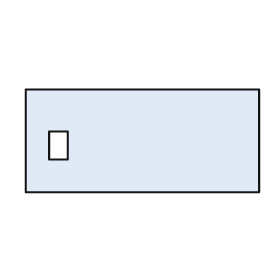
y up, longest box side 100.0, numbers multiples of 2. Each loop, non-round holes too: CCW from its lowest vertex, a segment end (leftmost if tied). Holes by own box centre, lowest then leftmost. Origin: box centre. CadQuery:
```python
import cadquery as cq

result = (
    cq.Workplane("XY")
    .moveTo(-50.0, -22.0)
    .lineTo(50.0, -22.0)
    .lineTo(50.0, 22.0)
    .lineTo(-50.0, 22.0)
    .close()
    .moveTo(-40.0, -8.0)
    .lineTo(-32.0, -8.0)
    .lineTo(-32.0, 4.0)
    .lineTo(-40.0, 4.0)
    .close()
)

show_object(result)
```